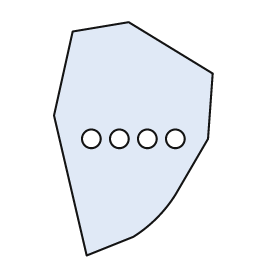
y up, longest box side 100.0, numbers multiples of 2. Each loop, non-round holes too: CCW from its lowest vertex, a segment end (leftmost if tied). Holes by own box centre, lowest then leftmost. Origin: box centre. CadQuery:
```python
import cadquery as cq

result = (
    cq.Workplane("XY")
    .moveTo(-20.0, -50.0)
    .lineTo(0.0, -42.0)
    .threePointArc((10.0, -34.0), (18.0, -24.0))
    .lineTo(32.0, 0.0)
    .lineTo(34.0, 28.0)
    .lineTo(-2.0, 50.0)
    .lineTo(-26.0, 46.0)
    .lineTo(-34.0, 10.0)
    .close()
    .moveTo(-18.0, 0.0)
    .circle(4.0)
    .moveTo(-6.0, 0.0)
    .circle(4.0)
    .moveTo(6.0, 0.0)
    .circle(4.0)
    .moveTo(18.0, 0.0)
    .circle(4.0)
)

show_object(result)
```